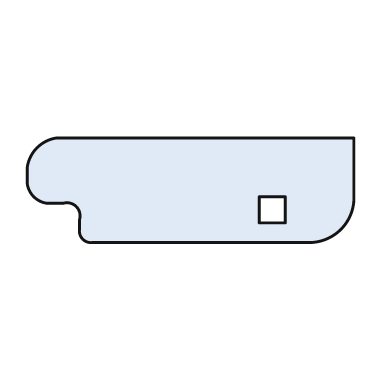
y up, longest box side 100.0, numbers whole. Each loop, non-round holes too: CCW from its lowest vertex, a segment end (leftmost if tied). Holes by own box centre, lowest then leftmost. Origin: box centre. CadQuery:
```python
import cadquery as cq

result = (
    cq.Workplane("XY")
    .moveTo(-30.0, -16.0)
    .lineTo(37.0, -16.0)
    .threePointArc((46.0, -12.0), (50.0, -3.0))
    .lineTo(50.0, 16.0)
    .lineTo(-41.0, 16.0)
    .threePointArc((-47.0, 13.0), (-50.0, 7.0))
    .lineTo(-50.0, 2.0)
    .threePointArc((-48.0, -2.0), (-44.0, -4.0))
    .lineTo(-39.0, -4.0)
    .threePointArc((-35.0, -5.0), (-34.0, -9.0))
    .lineTo(-34.0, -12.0)
    .threePointArc((-33.0, -15.0), (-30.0, -16.0))
    .close()
    .moveTo(21.0, -10.0)
    .lineTo(29.0, -10.0)
    .lineTo(29.0, -2.0)
    .lineTo(21.0, -2.0)
    .close()
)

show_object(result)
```